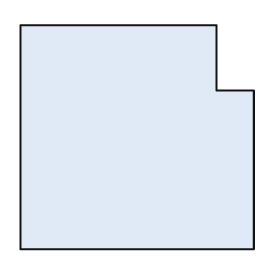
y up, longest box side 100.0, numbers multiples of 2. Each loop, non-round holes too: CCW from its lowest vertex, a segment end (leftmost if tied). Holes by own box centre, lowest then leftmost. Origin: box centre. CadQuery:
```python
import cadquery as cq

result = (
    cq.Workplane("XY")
    .moveTo(-50.0, -48.0)
    .lineTo(50.0, -48.0)
    .lineTo(50.0, 20.0)
    .lineTo(34.0, 20.0)
    .lineTo(34.0, 48.0)
    .lineTo(-50.0, 48.0)
    .close()
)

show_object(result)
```